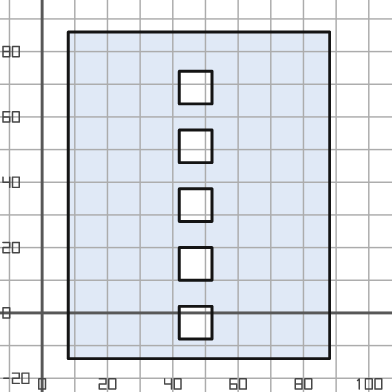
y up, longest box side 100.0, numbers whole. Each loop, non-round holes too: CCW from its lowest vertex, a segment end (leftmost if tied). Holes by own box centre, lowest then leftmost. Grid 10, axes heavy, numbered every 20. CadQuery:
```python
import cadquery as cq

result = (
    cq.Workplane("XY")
    .moveTo(8.0, -14.0)
    .lineTo(88.0, -14.0)
    .lineTo(88.0, 86.0)
    .lineTo(8.0, 86.0)
    .close()
    .moveTo(42.0, -8.0)
    .lineTo(52.0, -8.0)
    .lineTo(52.0, 2.0)
    .lineTo(42.0, 2.0)
    .close()
    .moveTo(42.0, 10.0)
    .lineTo(52.0, 10.0)
    .lineTo(52.0, 20.0)
    .lineTo(42.0, 20.0)
    .close()
    .moveTo(42.0, 28.0)
    .lineTo(52.0, 28.0)
    .lineTo(52.0, 38.0)
    .lineTo(42.0, 38.0)
    .close()
    .moveTo(42.0, 46.0)
    .lineTo(52.0, 46.0)
    .lineTo(52.0, 56.0)
    .lineTo(42.0, 56.0)
    .close()
    .moveTo(42.0, 64.0)
    .lineTo(52.0, 64.0)
    .lineTo(52.0, 74.0)
    .lineTo(42.0, 74.0)
    .close()
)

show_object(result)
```